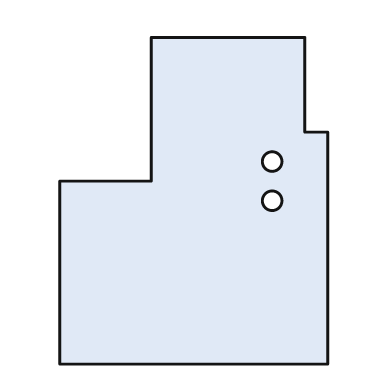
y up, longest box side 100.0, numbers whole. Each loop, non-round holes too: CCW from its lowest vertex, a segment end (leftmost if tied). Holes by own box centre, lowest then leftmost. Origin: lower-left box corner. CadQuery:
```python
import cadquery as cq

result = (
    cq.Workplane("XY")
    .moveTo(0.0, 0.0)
    .lineTo(82.0, 0.0)
    .lineTo(82.0, 71.0)
    .lineTo(75.0, 71.0)
    .lineTo(75.0, 100.0)
    .lineTo(28.0, 100.0)
    .lineTo(28.0, 56.0)
    .lineTo(0.0, 56.0)
    .close()
    .moveTo(65.0, 50.0)
    .circle(3.0)
    .moveTo(65.0, 62.0)
    .circle(3.0)
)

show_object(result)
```